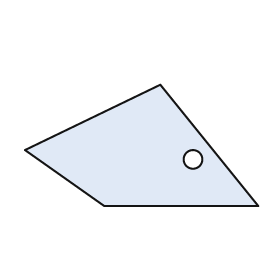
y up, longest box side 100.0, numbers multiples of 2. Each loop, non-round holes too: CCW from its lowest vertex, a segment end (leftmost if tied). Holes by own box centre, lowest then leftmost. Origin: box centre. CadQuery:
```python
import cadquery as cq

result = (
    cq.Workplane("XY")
    .moveTo(-16.0, -26.0)
    .lineTo(50.0, -26.0)
    .lineTo(8.0, 26.0)
    .lineTo(-50.0, -2.0)
    .close()
    .moveTo(22.0, -6.0)
    .circle(4.0)
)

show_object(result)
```